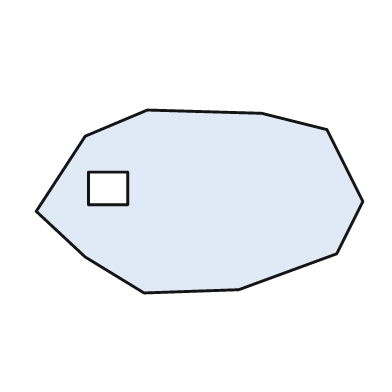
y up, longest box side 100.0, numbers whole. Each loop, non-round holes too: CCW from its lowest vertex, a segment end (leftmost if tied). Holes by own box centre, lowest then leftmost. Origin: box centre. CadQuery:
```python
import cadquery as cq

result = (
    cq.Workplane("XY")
    .moveTo(-17.0, -28.0)
    .lineTo(12.0, -27.0)
    .lineTo(42.0, -16.0)
    .lineTo(50.0, 0.0)
    .lineTo(39.0, 22.0)
    .lineTo(19.0, 27.0)
    .lineTo(-16.0, 28.0)
    .lineTo(-35.0, 20.0)
    .lineTo(-50.0, -3.0)
    .lineTo(-35.0, -17.0)
    .close()
    .moveTo(-34.0, -1.0)
    .lineTo(-22.0, -1.0)
    .lineTo(-22.0, 9.0)
    .lineTo(-34.0, 9.0)
    .close()
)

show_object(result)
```